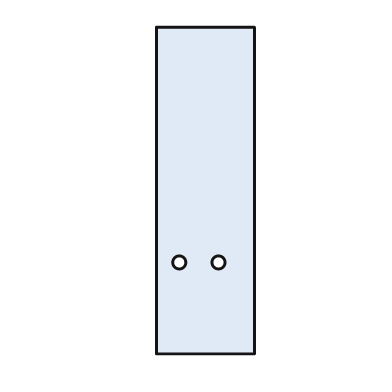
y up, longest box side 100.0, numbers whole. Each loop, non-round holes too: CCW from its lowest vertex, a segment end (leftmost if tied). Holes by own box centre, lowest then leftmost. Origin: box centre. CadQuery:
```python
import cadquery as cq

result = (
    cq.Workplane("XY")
    .moveTo(-15.0, -50.0)
    .lineTo(15.0, -50.0)
    .lineTo(15.0, 50.0)
    .lineTo(-15.0, 50.0)
    .close()
    .moveTo(-8.0, -22.0)
    .circle(2.0)
    .moveTo(4.0, -22.0)
    .circle(2.0)
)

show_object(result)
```